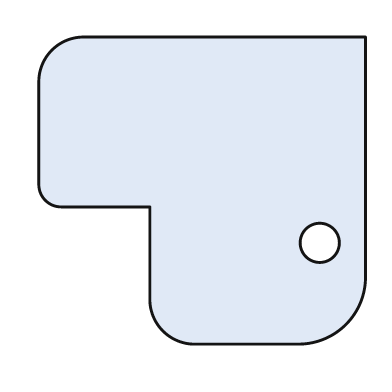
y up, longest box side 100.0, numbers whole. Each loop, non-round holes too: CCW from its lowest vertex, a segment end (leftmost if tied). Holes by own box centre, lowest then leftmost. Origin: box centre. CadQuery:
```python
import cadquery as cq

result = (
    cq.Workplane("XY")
    .moveTo(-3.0, -47.0)
    .lineTo(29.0, -47.0)
    .threePointArc((44.0, -41.0), (50.0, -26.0))
    .lineTo(50.0, 47.0)
    .lineTo(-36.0, 47.0)
    .threePointArc((-46.0, 43.0), (-50.0, 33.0))
    .lineTo(-50.0, 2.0)
    .threePointArc((-48.0, -3.0), (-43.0, -5.0))
    .lineTo(-16.0, -5.0)
    .lineTo(-16.0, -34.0)
    .threePointArc((-12.0, -43.0), (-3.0, -47.0))
    .close()
    .moveTo(36.0, -16.0)
    .circle(6.0)
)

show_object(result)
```